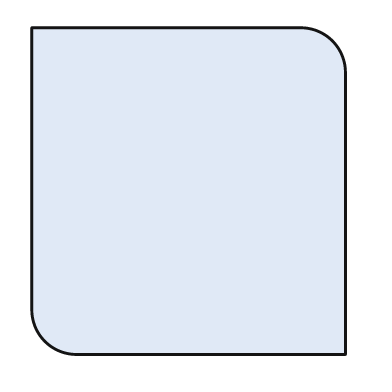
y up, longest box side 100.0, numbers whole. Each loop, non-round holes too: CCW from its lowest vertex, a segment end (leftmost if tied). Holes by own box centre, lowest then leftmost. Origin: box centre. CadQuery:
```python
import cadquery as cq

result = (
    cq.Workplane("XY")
    .moveTo(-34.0, -50.0)
    .lineTo(48.0, -50.0)
    .lineTo(48.0, 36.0)
    .threePointArc((44.0, 46.0), (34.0, 50.0))
    .lineTo(-48.0, 50.0)
    .lineTo(-48.0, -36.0)
    .threePointArc((-44.0, -46.0), (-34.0, -50.0))
    .close()
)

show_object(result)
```